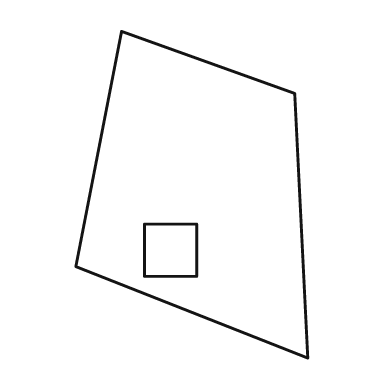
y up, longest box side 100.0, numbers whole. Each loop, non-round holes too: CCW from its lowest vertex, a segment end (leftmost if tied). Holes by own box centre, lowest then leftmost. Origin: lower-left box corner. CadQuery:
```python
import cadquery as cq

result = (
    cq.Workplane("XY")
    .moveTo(71.0, 0.0)
    .lineTo(67.0, 81.0)
    .lineTo(14.0, 100.0)
    .lineTo(0.0, 28.0)
    .close()
    .moveTo(21.0, 25.0)
    .lineTo(37.0, 25.0)
    .lineTo(37.0, 41.0)
    .lineTo(21.0, 41.0)
    .close()
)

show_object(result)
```